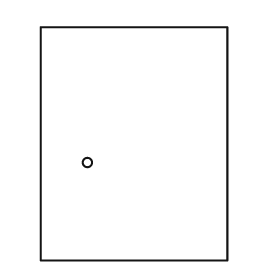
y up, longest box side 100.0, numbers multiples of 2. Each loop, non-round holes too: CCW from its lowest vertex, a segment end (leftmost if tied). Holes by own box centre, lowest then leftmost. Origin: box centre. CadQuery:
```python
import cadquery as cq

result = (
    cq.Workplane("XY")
    .moveTo(-40.0, -50.0)
    .lineTo(40.0, -50.0)
    .lineTo(40.0, 50.0)
    .lineTo(-40.0, 50.0)
    .close()
    .moveTo(-20.0, -8.0)
    .circle(2.0)
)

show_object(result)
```